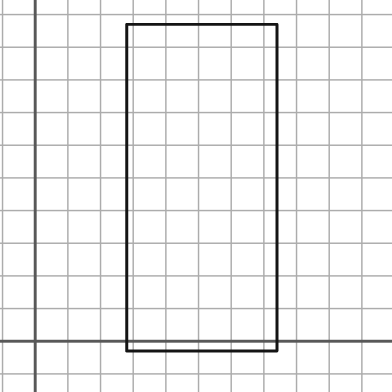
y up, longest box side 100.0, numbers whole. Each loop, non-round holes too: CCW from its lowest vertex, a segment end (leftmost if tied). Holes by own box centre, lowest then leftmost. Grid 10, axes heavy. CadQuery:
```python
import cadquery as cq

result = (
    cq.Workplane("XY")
    .moveTo(28.0, -3.0)
    .lineTo(74.0, -3.0)
    .lineTo(74.0, 97.0)
    .lineTo(28.0, 97.0)
    .close()
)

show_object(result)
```